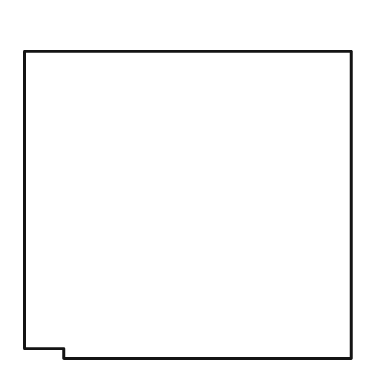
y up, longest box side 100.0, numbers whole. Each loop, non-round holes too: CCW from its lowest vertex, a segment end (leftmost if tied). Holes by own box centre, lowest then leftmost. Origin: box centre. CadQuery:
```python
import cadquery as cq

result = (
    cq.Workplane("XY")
    .moveTo(-38.0, -47.0)
    .lineTo(50.0, -47.0)
    .lineTo(50.0, 47.0)
    .lineTo(-50.0, 47.0)
    .lineTo(-50.0, -44.0)
    .lineTo(-38.0, -44.0)
    .close()
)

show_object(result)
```